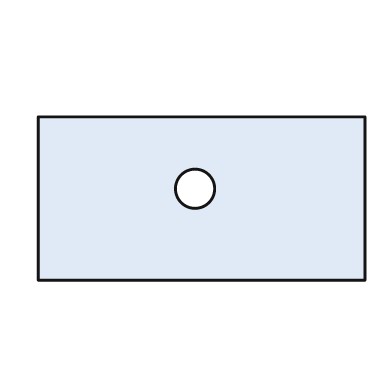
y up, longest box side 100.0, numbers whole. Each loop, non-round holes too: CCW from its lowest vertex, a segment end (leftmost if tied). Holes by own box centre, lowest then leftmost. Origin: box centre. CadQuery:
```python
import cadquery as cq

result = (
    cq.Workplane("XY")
    .moveTo(-50.0, -25.0)
    .lineTo(50.0, -25.0)
    .lineTo(50.0, 25.0)
    .lineTo(-50.0, 25.0)
    .close()
    .moveTo(-2.0, 3.0)
    .circle(6.0)
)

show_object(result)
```